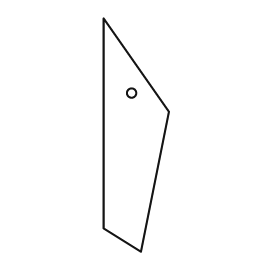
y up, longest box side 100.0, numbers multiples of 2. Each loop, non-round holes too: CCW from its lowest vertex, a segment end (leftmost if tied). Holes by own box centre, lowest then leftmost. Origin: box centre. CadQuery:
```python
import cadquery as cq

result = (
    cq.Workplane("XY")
    .moveTo(2.0, -50.0)
    .lineTo(14.0, 10.0)
    .lineTo(-14.0, 50.0)
    .lineTo(-14.0, -40.0)
    .close()
    .moveTo(-2.0, 18.0)
    .circle(2.0)
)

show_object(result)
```